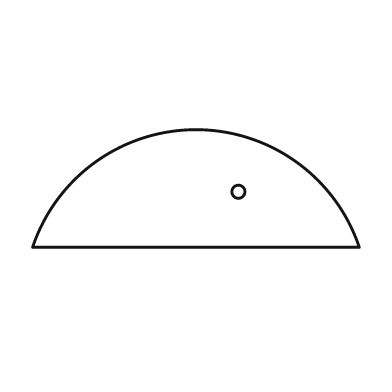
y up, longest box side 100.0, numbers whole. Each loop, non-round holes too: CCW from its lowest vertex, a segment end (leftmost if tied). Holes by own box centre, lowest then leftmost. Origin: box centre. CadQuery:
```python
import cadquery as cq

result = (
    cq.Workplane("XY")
    .moveTo(-50.0, -18.0)
    .lineTo(50.0, -18.0)
    .threePointArc((0.0, 18.0), (-50.0, -18.0))
    .close()
    .moveTo(13.0, -1.0)
    .circle(2.0)
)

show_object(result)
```